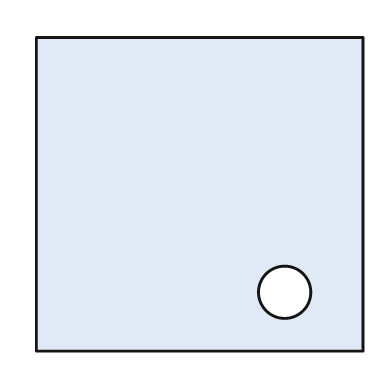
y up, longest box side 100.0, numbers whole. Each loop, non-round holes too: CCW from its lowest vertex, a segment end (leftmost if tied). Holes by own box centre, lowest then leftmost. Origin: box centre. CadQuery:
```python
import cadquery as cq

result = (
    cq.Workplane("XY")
    .moveTo(-50.0, -48.0)
    .lineTo(50.0, -48.0)
    .lineTo(50.0, 48.0)
    .lineTo(-50.0, 48.0)
    .close()
    .moveTo(26.0, -30.0)
    .circle(8.0)
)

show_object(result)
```